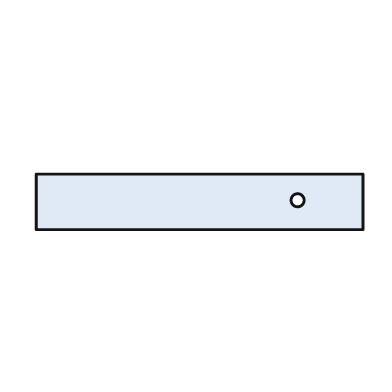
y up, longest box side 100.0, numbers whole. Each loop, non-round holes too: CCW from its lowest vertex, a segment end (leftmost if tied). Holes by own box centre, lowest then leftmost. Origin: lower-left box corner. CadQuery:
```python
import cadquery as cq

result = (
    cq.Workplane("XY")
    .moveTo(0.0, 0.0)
    .lineTo(100.0, 0.0)
    .lineTo(100.0, 17.0)
    .lineTo(0.0, 17.0)
    .close()
    .moveTo(80.0, 9.0)
    .circle(2.0)
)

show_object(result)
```